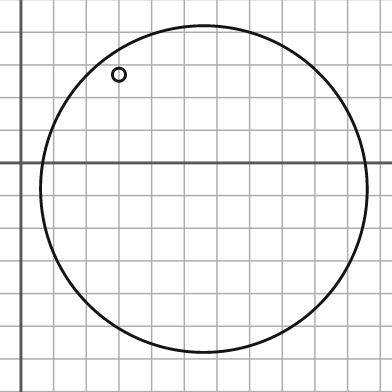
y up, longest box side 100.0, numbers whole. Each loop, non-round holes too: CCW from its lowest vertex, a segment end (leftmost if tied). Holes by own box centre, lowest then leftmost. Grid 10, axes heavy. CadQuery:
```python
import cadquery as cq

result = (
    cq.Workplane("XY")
    .moveTo(56.0, -8.0)
    .circle(50.0)
    .moveTo(30.0, 27.0)
    .circle(2.0)
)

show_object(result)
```